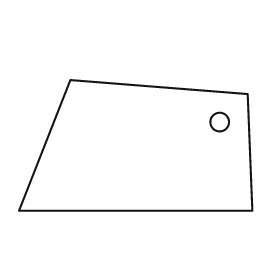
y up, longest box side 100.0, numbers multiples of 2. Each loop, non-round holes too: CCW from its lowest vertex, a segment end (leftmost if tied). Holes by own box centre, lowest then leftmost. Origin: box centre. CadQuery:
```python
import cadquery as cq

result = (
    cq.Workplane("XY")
    .moveTo(-50.0, -28.0)
    .lineTo(50.0, -28.0)
    .lineTo(48.0, 22.0)
    .lineTo(-28.0, 28.0)
    .close()
    .moveTo(36.0, 10.0)
    .circle(4.0)
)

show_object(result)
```